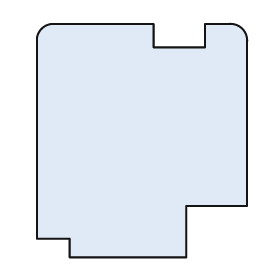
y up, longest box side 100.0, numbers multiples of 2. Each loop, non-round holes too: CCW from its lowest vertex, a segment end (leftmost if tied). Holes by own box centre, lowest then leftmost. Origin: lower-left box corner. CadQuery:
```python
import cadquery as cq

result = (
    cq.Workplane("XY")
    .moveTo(14.0, 0.0)
    .lineTo(64.0, 0.0)
    .lineTo(64.0, 22.0)
    .lineTo(90.0, 22.0)
    .lineTo(90.0, 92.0)
    .threePointArc((88.0, 98.0), (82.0, 100.0))
    .lineTo(72.0, 100.0)
    .lineTo(72.0, 90.0)
    .lineTo(50.0, 90.0)
    .lineTo(50.0, 100.0)
    .lineTo(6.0, 100.0)
    .threePointArc((2.0, 98.0), (0.0, 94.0))
    .lineTo(0.0, 8.0)
    .lineTo(14.0, 8.0)
    .close()
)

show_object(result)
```